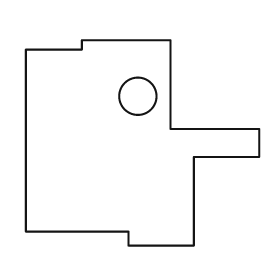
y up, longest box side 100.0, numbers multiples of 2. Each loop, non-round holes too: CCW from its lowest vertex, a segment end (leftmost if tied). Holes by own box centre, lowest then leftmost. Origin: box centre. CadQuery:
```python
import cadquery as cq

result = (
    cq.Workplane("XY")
    .moveTo(-6.0, -44.0)
    .lineTo(22.0, -44.0)
    .lineTo(22.0, -6.0)
    .lineTo(50.0, -6.0)
    .lineTo(50.0, 6.0)
    .lineTo(12.0, 6.0)
    .lineTo(12.0, 44.0)
    .lineTo(-26.0, 44.0)
    .lineTo(-26.0, 40.0)
    .lineTo(-50.0, 40.0)
    .lineTo(-50.0, -38.0)
    .lineTo(-6.0, -38.0)
    .close()
    .moveTo(-2.0, 20.0)
    .circle(8.0)
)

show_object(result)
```